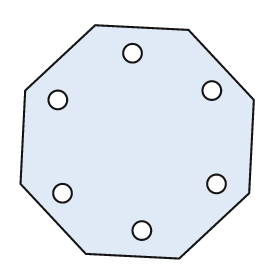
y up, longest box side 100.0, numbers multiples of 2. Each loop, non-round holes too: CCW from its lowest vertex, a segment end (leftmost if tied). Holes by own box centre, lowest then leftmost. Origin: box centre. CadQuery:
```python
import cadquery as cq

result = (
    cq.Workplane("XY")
    .moveTo(18.0, -50.0)
    .lineTo(48.0, -22.0)
    .lineTo(50.0, 18.0)
    .lineTo(22.0, 48.0)
    .lineTo(-18.0, 50.0)
    .lineTo(-48.0, 22.0)
    .lineTo(-50.0, -18.0)
    .lineTo(-22.0, -48.0)
    .close()
    .moveTo(2.0, -38.0)
    .circle(4.0)
    .moveTo(-32.0, -22.0)
    .circle(4.0)
    .moveTo(34.0, -18.0)
    .circle(4.0)
    .moveTo(-34.0, 18.0)
    .circle(4.0)
    .moveTo(32.0, 22.0)
    .circle(4.0)
    .moveTo(-2.0, 38.0)
    .circle(4.0)
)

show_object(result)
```